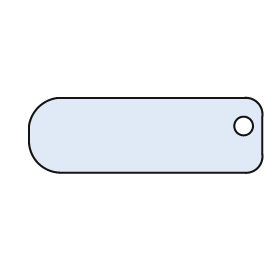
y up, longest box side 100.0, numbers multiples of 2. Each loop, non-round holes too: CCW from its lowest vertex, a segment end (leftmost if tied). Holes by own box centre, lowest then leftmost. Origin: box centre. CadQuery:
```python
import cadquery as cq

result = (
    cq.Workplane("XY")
    .moveTo(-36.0, -16.0)
    .lineTo(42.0, -16.0)
    .threePointArc((48.0, -14.0), (50.0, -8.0))
    .lineTo(50.0, 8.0)
    .threePointArc((48.0, 14.0), (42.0, 16.0))
    .lineTo(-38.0, 16.0)
    .threePointArc((-46.0, 12.0), (-50.0, 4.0))
    .lineTo(-50.0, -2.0)
    .threePointArc((-46.0, -12.0), (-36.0, -16.0))
    .close()
    .moveTo(42.0, 4.0)
    .circle(4.0)
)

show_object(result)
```